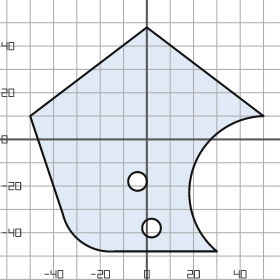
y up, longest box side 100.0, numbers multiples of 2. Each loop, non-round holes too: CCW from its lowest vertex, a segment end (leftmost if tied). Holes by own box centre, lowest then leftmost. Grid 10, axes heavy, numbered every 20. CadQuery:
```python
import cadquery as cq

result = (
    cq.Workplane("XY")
    .moveTo(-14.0, -48.0)
    .lineTo(30.0, -48.0)
    .threePointArc((20.0, -12.0), (50.0, 10.0))
    .lineTo(0.0, 48.0)
    .lineTo(-50.0, 10.0)
    .lineTo(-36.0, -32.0)
    .threePointArc((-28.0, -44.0), (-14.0, -48.0))
    .close()
    .moveTo(2.0, -38.0)
    .circle(4.0)
    .moveTo(-4.0, -18.0)
    .circle(4.0)
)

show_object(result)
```